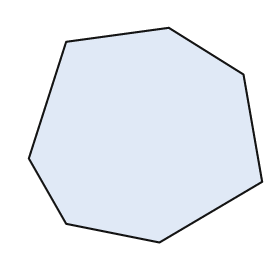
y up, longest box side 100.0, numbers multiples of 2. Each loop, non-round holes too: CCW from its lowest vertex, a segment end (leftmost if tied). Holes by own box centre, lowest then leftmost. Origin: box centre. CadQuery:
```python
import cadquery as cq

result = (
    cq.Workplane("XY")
    .moveTo(6.0, -46.0)
    .lineTo(50.0, -20.0)
    .lineTo(42.0, 26.0)
    .lineTo(10.0, 46.0)
    .lineTo(-34.0, 40.0)
    .lineTo(-50.0, -10.0)
    .lineTo(-34.0, -38.0)
    .close()
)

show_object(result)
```